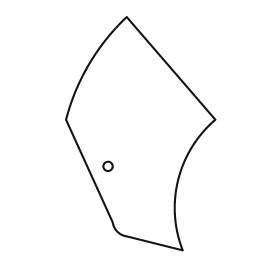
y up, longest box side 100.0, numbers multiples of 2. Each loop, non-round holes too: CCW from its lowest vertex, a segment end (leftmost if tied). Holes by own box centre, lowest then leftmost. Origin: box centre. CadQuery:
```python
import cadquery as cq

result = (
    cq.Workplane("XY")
    .moveTo(18.0, -50.0)
    .threePointArc((16.0, -20.0), (32.0, 6.0))
    .lineTo(-6.0, 50.0)
    .threePointArc((-22.0, 30.0), (-32.0, 6.0))
    .lineTo(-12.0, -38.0)
    .threePointArc((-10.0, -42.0), (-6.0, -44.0))
    .close()
    .moveTo(-14.0, -14.0)
    .circle(2.0)
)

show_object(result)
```